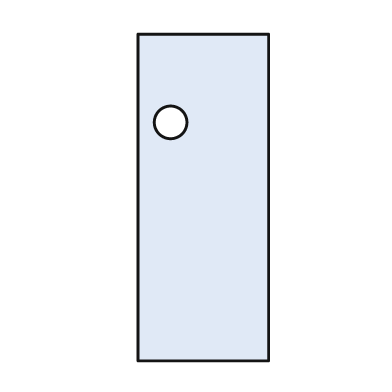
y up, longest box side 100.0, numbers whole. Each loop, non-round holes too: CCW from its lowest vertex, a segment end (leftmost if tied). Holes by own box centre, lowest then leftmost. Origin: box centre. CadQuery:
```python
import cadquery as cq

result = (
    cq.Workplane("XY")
    .moveTo(-20.0, -50.0)
    .lineTo(20.0, -50.0)
    .lineTo(20.0, 50.0)
    .lineTo(-20.0, 50.0)
    .close()
    .moveTo(-10.0, 23.0)
    .circle(5.0)
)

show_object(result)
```